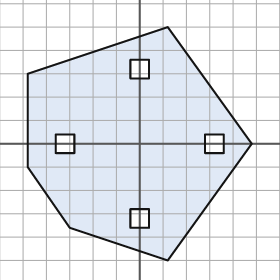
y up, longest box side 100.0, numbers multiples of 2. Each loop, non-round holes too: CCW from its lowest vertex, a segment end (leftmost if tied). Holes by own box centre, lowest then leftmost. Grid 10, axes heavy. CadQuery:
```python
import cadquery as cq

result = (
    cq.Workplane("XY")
    .moveTo(12.0, -50.0)
    .lineTo(48.0, 0.0)
    .lineTo(12.0, 50.0)
    .lineTo(-48.0, 30.0)
    .lineTo(-48.0, -10.0)
    .lineTo(-30.0, -36.0)
    .close()
    .moveTo(-4.0, -36.0)
    .lineTo(4.0, -36.0)
    .lineTo(4.0, -28.0)
    .lineTo(-4.0, -28.0)
    .close()
    .moveTo(-36.0, -4.0)
    .lineTo(-28.0, -4.0)
    .lineTo(-28.0, 4.0)
    .lineTo(-36.0, 4.0)
    .close()
    .moveTo(28.0, -4.0)
    .lineTo(36.0, -4.0)
    .lineTo(36.0, 4.0)
    .lineTo(28.0, 4.0)
    .close()
    .moveTo(-4.0, 28.0)
    .lineTo(4.0, 28.0)
    .lineTo(4.0, 36.0)
    .lineTo(-4.0, 36.0)
    .close()
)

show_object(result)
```